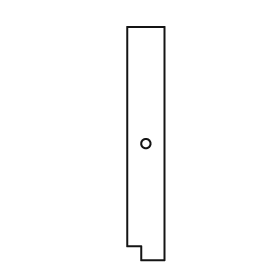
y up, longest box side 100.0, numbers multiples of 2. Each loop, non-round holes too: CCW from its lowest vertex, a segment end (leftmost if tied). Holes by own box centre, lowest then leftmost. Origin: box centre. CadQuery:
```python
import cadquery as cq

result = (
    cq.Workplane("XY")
    .moveTo(-2.0, -50.0)
    .lineTo(8.0, -50.0)
    .lineTo(8.0, 50.0)
    .lineTo(-8.0, 50.0)
    .lineTo(-8.0, -44.0)
    .lineTo(-2.0, -44.0)
    .close()
    .moveTo(0.0, 0.0)
    .circle(2.0)
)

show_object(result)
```